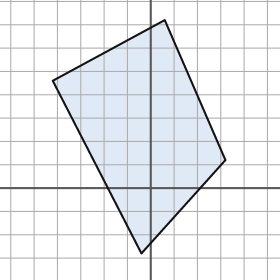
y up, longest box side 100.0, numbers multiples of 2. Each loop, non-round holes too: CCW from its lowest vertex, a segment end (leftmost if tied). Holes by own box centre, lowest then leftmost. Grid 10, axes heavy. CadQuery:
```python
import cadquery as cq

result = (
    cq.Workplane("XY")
    .moveTo(-4.0, -28.0)
    .lineTo(32.0, 12.0)
    .lineTo(6.0, 72.0)
    .lineTo(-42.0, 46.0)
    .close()
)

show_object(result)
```